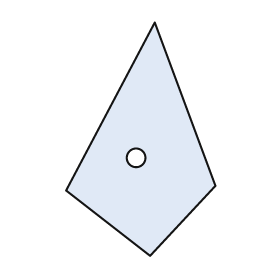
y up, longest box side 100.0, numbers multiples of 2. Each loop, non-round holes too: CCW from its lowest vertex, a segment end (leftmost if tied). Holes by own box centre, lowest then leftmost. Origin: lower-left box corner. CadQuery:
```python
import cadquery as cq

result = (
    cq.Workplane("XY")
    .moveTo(36.0, 0.0)
    .lineTo(64.0, 30.0)
    .lineTo(38.0, 100.0)
    .lineTo(0.0, 28.0)
    .close()
    .moveTo(30.0, 42.0)
    .circle(4.0)
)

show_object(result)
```